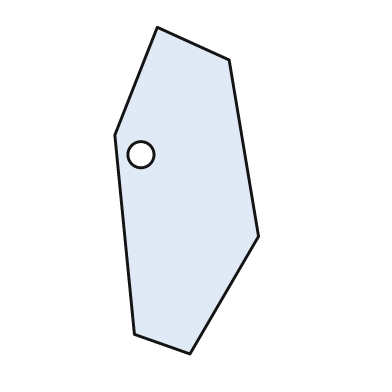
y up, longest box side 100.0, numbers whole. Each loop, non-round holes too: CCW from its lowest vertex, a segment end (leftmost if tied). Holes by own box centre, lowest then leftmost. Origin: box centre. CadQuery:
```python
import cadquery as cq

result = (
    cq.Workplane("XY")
    .moveTo(1.0, -50.0)
    .lineTo(22.0, -14.0)
    .lineTo(13.0, 40.0)
    .lineTo(-9.0, 50.0)
    .lineTo(-22.0, 17.0)
    .lineTo(-16.0, -44.0)
    .close()
    .moveTo(-14.0, 11.0)
    .circle(4.0)
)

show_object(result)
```